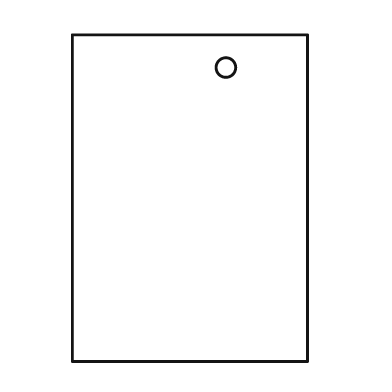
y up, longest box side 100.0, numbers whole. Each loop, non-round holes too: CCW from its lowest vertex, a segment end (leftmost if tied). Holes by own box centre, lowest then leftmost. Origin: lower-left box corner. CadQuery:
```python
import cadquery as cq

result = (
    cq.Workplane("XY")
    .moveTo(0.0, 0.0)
    .lineTo(72.0, 0.0)
    .lineTo(72.0, 100.0)
    .lineTo(0.0, 100.0)
    .close()
    .moveTo(47.0, 90.0)
    .circle(3.0)
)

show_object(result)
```